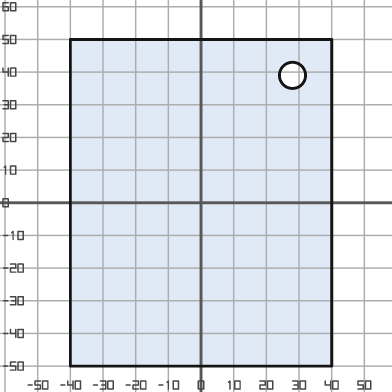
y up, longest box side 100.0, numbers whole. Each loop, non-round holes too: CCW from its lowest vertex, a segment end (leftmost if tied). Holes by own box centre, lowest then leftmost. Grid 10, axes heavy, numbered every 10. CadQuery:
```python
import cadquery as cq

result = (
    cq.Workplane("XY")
    .moveTo(-40.0, -50.0)
    .lineTo(40.0, -50.0)
    .lineTo(40.0, 50.0)
    .lineTo(-40.0, 50.0)
    .close()
    .moveTo(28.0, 39.0)
    .circle(4.0)
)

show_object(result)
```